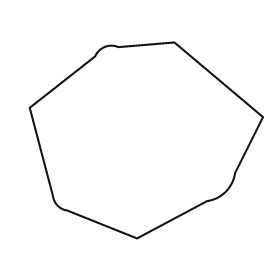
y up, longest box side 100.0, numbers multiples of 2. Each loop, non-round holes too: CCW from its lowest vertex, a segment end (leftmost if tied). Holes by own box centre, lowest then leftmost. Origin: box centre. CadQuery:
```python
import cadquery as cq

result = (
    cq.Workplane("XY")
    .moveTo(-4.0, -42.0)
    .lineTo(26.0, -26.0)
    .threePointArc((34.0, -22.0), (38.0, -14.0))
    .lineTo(50.0, 10.0)
    .lineTo(12.0, 42.0)
    .lineTo(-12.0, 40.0)
    .threePointArc((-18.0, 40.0), (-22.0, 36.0))
    .lineTo(-50.0, 14.0)
    .lineTo(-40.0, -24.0)
    .threePointArc((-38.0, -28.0), (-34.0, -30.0))
    .close()
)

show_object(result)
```